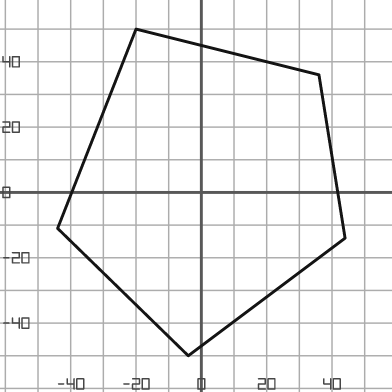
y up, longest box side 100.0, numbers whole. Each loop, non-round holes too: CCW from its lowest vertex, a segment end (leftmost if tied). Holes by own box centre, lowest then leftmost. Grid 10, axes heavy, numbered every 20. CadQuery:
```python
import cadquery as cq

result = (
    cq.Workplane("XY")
    .moveTo(-4.0, -50.0)
    .lineTo(44.0, -14.0)
    .lineTo(36.0, 36.0)
    .lineTo(-20.0, 50.0)
    .lineTo(-44.0, -11.0)
    .close()
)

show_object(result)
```